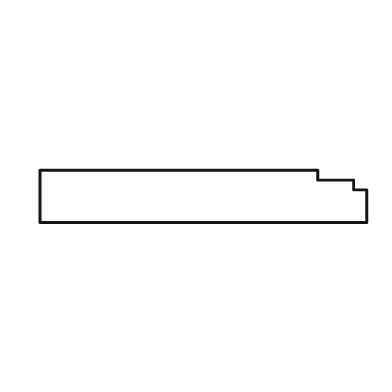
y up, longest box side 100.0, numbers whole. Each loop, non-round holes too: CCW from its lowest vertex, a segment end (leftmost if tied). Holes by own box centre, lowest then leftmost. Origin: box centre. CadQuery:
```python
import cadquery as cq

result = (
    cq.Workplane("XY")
    .moveTo(-50.0, -8.0)
    .lineTo(50.0, -8.0)
    .lineTo(50.0, 2.0)
    .lineTo(46.0, 2.0)
    .lineTo(46.0, 5.0)
    .lineTo(35.0, 5.0)
    .lineTo(35.0, 8.0)
    .lineTo(-50.0, 8.0)
    .close()
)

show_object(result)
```